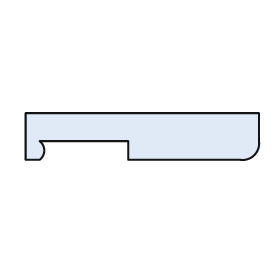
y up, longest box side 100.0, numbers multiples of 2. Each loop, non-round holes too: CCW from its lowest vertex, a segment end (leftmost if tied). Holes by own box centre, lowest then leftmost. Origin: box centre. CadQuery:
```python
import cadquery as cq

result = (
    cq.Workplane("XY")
    .moveTo(-50.0, -10.0)
    .lineTo(-44.0, -10.0)
    .threePointArc((-42.0, -6.0), (-44.0, -2.0))
    .lineTo(-6.0, -2.0)
    .lineTo(-6.0, -10.0)
    .lineTo(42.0, -10.0)
    .threePointArc((48.0, -8.0), (50.0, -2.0))
    .lineTo(50.0, 10.0)
    .lineTo(-50.0, 10.0)
    .close()
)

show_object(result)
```